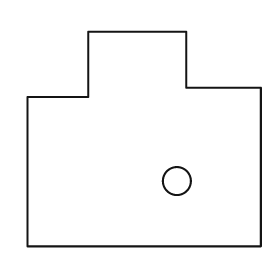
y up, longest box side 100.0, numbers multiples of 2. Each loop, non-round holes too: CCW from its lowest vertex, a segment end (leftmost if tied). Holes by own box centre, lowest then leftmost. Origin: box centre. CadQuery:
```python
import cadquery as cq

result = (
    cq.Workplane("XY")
    .moveTo(-50.0, -46.0)
    .lineTo(50.0, -46.0)
    .lineTo(50.0, 22.0)
    .lineTo(18.0, 22.0)
    .lineTo(18.0, 46.0)
    .lineTo(-24.0, 46.0)
    .lineTo(-24.0, 18.0)
    .lineTo(-50.0, 18.0)
    .close()
    .moveTo(14.0, -18.0)
    .circle(6.0)
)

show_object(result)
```